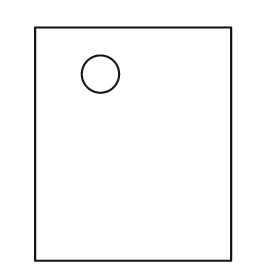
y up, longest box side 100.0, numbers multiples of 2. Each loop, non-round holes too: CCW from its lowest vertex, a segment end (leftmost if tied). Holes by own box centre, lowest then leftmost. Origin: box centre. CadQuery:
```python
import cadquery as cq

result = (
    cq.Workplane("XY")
    .moveTo(-42.0, -50.0)
    .lineTo(42.0, -50.0)
    .lineTo(42.0, 50.0)
    .lineTo(-42.0, 50.0)
    .close()
    .moveTo(-14.0, 30.0)
    .circle(8.0)
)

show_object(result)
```